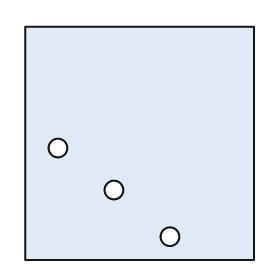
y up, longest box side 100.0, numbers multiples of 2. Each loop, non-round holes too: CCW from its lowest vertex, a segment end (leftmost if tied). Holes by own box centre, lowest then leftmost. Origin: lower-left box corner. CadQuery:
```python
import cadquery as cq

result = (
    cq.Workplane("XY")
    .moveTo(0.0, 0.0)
    .lineTo(98.0, 0.0)
    .lineTo(98.0, 100.0)
    .lineTo(0.0, 100.0)
    .close()
    .moveTo(62.0, 10.0)
    .circle(4.0)
    .moveTo(38.0, 30.0)
    .circle(4.0)
    .moveTo(14.0, 48.0)
    .circle(4.0)
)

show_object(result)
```